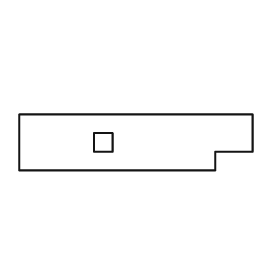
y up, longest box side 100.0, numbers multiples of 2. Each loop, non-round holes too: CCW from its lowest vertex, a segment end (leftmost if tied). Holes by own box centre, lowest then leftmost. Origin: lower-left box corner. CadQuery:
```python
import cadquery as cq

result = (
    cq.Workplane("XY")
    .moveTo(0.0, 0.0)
    .lineTo(84.0, 0.0)
    .lineTo(84.0, 8.0)
    .lineTo(100.0, 8.0)
    .lineTo(100.0, 24.0)
    .lineTo(0.0, 24.0)
    .close()
    .moveTo(32.0, 8.0)
    .lineTo(40.0, 8.0)
    .lineTo(40.0, 16.0)
    .lineTo(32.0, 16.0)
    .close()
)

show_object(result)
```